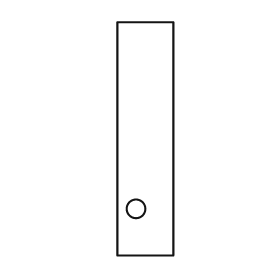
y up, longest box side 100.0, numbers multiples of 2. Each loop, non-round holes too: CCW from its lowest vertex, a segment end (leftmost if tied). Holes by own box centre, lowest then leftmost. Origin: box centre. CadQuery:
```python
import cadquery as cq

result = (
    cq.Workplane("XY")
    .moveTo(-12.0, -50.0)
    .lineTo(12.0, -50.0)
    .lineTo(12.0, 50.0)
    .lineTo(-12.0, 50.0)
    .close()
    .moveTo(-4.0, -30.0)
    .circle(4.0)
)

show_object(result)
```